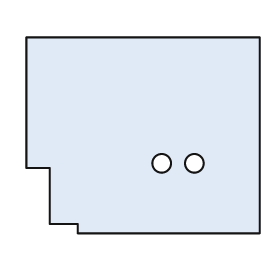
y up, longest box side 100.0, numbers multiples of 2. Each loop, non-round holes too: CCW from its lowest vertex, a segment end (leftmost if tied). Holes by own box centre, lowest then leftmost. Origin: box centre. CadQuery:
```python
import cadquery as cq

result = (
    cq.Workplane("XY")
    .moveTo(-28.0, -42.0)
    .lineTo(50.0, -42.0)
    .lineTo(50.0, 42.0)
    .lineTo(-50.0, 42.0)
    .lineTo(-50.0, -14.0)
    .lineTo(-40.0, -14.0)
    .lineTo(-40.0, -38.0)
    .lineTo(-28.0, -38.0)
    .close()
    .moveTo(8.0, -12.0)
    .circle(4.0)
    .moveTo(22.0, -12.0)
    .circle(4.0)
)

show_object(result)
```